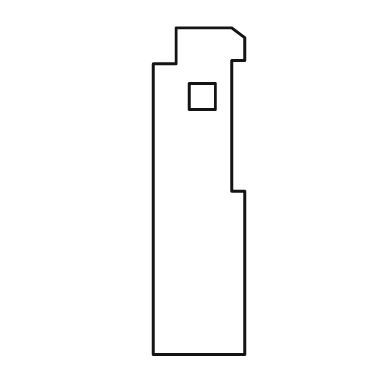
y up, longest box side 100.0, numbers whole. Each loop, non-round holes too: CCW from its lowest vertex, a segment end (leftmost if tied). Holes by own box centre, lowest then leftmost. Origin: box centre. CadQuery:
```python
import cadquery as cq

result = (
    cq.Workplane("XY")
    .moveTo(-14.0, -50.0)
    .lineTo(14.0, -50.0)
    .lineTo(14.0, 0.0)
    .lineTo(10.0, 0.0)
    .lineTo(10.0, 40.0)
    .lineTo(14.0, 40.0)
    .lineTo(14.0, 47.0)
    .lineTo(10.0, 50.0)
    .lineTo(-7.0, 50.0)
    .lineTo(-7.0, 39.0)
    .lineTo(-14.0, 39.0)
    .close()
    .moveTo(-3.0, 25.0)
    .lineTo(5.0, 25.0)
    .lineTo(5.0, 33.0)
    .lineTo(-3.0, 33.0)
    .close()
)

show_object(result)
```